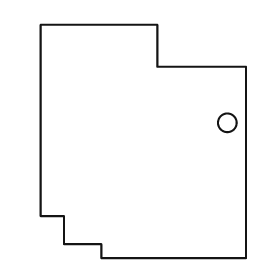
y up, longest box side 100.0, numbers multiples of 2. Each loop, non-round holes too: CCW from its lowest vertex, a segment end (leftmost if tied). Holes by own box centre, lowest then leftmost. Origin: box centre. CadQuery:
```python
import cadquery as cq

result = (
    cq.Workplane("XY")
    .moveTo(-18.0, -50.0)
    .lineTo(44.0, -50.0)
    .lineTo(44.0, 32.0)
    .lineTo(6.0, 32.0)
    .lineTo(6.0, 50.0)
    .lineTo(-44.0, 50.0)
    .lineTo(-44.0, -32.0)
    .lineTo(-34.0, -32.0)
    .lineTo(-34.0, -44.0)
    .lineTo(-18.0, -44.0)
    .close()
    .moveTo(36.0, 8.0)
    .circle(4.0)
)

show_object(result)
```